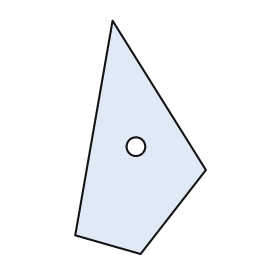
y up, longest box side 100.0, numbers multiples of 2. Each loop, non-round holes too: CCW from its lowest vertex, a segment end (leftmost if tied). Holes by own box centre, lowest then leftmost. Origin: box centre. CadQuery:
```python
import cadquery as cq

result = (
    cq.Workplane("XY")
    .moveTo(0.0, -50.0)
    .lineTo(28.0, -14.0)
    .lineTo(-12.0, 50.0)
    .lineTo(-28.0, -42.0)
    .close()
    .moveTo(-2.0, -4.0)
    .circle(4.0)
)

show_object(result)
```